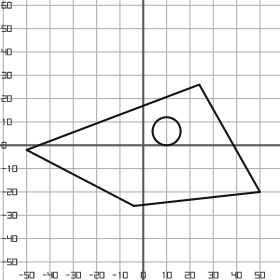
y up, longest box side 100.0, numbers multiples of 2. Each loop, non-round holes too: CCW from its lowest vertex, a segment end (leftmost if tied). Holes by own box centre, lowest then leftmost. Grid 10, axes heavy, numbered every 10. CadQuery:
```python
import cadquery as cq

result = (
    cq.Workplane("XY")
    .moveTo(-4.0, -26.0)
    .lineTo(50.0, -20.0)
    .lineTo(24.0, 26.0)
    .lineTo(-50.0, -2.0)
    .close()
    .moveTo(10.0, 6.0)
    .circle(6.0)
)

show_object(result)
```